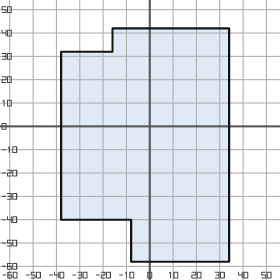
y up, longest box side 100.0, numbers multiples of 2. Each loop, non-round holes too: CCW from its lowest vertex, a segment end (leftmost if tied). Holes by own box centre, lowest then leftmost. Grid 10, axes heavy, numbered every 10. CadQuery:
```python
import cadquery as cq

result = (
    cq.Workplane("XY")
    .moveTo(-8.0, -58.0)
    .lineTo(34.0, -58.0)
    .lineTo(34.0, 42.0)
    .lineTo(-16.0, 42.0)
    .lineTo(-16.0, 32.0)
    .lineTo(-38.0, 32.0)
    .lineTo(-38.0, -40.0)
    .lineTo(-8.0, -40.0)
    .close()
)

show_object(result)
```